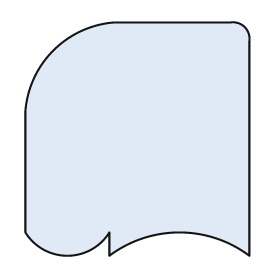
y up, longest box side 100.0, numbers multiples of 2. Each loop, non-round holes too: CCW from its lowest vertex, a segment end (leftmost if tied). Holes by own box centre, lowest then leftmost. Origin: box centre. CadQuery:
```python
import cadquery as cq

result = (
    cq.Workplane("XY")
    .moveTo(-12.0, -50.0)
    .threePointArc((18.0, -40.0), (48.0, -50.0))
    .lineTo(48.0, 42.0)
    .threePointArc((46.0, 48.0), (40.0, 50.0))
    .lineTo(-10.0, 50.0)
    .threePointArc((-36.0, 38.0), (-48.0, 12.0))
    .lineTo(-48.0, -40.0)
    .threePointArc((-30.0, -50.0), (-12.0, -40.0))
    .close()
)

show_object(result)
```